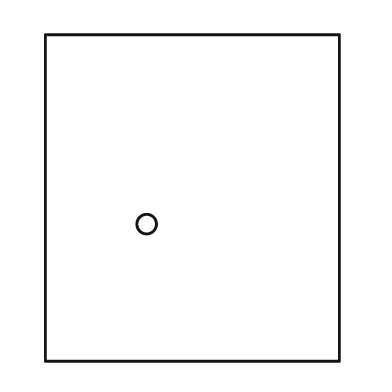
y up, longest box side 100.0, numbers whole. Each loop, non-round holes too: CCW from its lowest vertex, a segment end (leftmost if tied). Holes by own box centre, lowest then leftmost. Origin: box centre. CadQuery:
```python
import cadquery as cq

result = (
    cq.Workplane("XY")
    .moveTo(-45.0, -50.0)
    .lineTo(45.0, -50.0)
    .lineTo(45.0, 50.0)
    .lineTo(-45.0, 50.0)
    .close()
    .moveTo(-14.0, -8.0)
    .circle(3.0)
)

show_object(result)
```